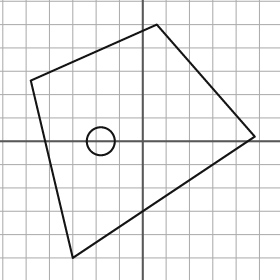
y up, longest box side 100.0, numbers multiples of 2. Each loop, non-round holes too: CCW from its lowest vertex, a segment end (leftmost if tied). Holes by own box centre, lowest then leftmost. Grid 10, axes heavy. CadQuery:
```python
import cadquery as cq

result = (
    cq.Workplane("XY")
    .moveTo(-30.0, -50.0)
    .lineTo(48.0, 2.0)
    .lineTo(6.0, 50.0)
    .lineTo(-48.0, 26.0)
    .close()
    .moveTo(-18.0, 0.0)
    .circle(6.0)
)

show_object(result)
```